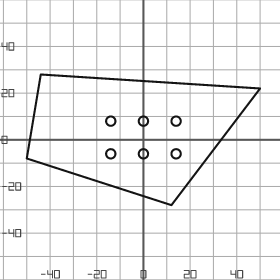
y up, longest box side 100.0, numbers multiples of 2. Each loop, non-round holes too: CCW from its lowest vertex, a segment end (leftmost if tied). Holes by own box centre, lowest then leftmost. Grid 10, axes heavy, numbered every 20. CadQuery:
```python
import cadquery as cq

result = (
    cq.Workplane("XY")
    .moveTo(12.0, -28.0)
    .lineTo(50.0, 22.0)
    .lineTo(-44.0, 28.0)
    .lineTo(-50.0, -8.0)
    .close()
    .moveTo(-14.0, -6.0)
    .circle(2.0)
    .moveTo(0.0, -6.0)
    .circle(2.0)
    .moveTo(14.0, -6.0)
    .circle(2.0)
    .moveTo(-14.0, 8.0)
    .circle(2.0)
    .moveTo(0.0, 8.0)
    .circle(2.0)
    .moveTo(14.0, 8.0)
    .circle(2.0)
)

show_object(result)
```